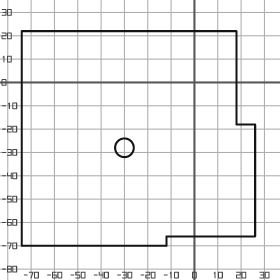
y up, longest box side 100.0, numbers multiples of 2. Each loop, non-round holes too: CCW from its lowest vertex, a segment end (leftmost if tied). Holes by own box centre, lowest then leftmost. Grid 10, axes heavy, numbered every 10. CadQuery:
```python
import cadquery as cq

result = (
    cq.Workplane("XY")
    .moveTo(-74.0, -70.0)
    .lineTo(-12.0, -70.0)
    .lineTo(-12.0, -66.0)
    .lineTo(26.0, -66.0)
    .lineTo(26.0, -18.0)
    .lineTo(18.0, -18.0)
    .lineTo(18.0, 22.0)
    .lineTo(-74.0, 22.0)
    .close()
    .moveTo(-30.0, -28.0)
    .circle(4.0)
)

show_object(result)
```